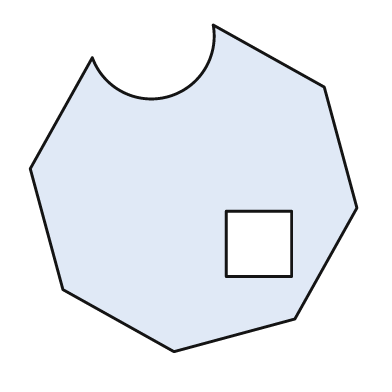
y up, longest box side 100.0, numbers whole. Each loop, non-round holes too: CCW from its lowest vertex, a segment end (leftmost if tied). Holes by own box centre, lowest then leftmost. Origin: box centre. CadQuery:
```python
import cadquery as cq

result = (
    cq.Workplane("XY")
    .moveTo(-6.0, -50.0)
    .lineTo(31.0, -40.0)
    .lineTo(50.0, -6.0)
    .lineTo(40.0, 31.0)
    .lineTo(6.0, 50.0)
    .threePointArc((-8.0, 28.0), (-31.0, 40.0))
    .lineTo(-50.0, 6.0)
    .lineTo(-40.0, -31.0)
    .close()
    .moveTo(10.0, -27.0)
    .lineTo(30.0, -27.0)
    .lineTo(30.0, -7.0)
    .lineTo(10.0, -7.0)
    .close()
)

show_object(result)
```